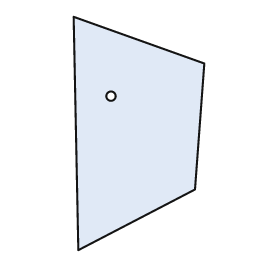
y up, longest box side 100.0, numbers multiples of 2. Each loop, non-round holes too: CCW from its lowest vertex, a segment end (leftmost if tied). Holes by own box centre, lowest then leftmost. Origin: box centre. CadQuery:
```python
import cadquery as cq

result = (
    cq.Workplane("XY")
    .moveTo(-26.0, -50.0)
    .lineTo(24.0, -24.0)
    .lineTo(28.0, 30.0)
    .lineTo(-28.0, 50.0)
    .close()
    .moveTo(-12.0, 16.0)
    .circle(2.0)
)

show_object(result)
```